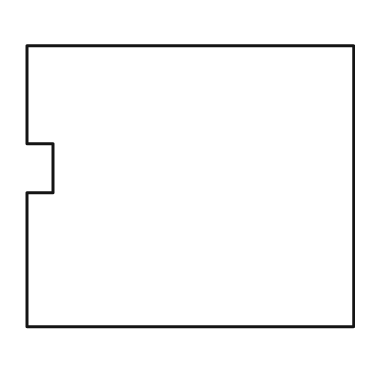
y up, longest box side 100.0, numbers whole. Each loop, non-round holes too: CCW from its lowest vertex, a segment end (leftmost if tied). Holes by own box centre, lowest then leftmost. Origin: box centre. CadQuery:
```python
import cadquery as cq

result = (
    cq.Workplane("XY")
    .moveTo(-50.0, -43.0)
    .lineTo(50.0, -43.0)
    .lineTo(50.0, 43.0)
    .lineTo(-50.0, 43.0)
    .lineTo(-50.0, 13.0)
    .lineTo(-42.0, 13.0)
    .lineTo(-42.0, -2.0)
    .lineTo(-50.0, -2.0)
    .close()
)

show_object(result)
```